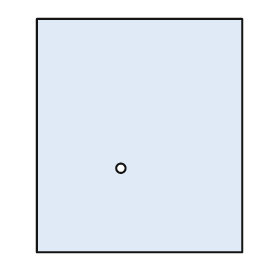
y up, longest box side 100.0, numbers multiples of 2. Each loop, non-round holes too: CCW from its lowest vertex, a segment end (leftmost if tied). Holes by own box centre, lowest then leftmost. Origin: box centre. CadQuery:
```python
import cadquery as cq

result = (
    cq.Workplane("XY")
    .moveTo(-44.0, -50.0)
    .lineTo(44.0, -50.0)
    .lineTo(44.0, 50.0)
    .lineTo(-44.0, 50.0)
    .close()
    .moveTo(-8.0, -14.0)
    .circle(2.0)
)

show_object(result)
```